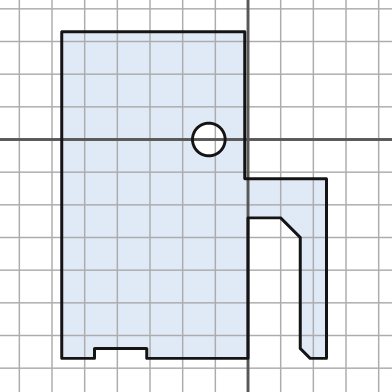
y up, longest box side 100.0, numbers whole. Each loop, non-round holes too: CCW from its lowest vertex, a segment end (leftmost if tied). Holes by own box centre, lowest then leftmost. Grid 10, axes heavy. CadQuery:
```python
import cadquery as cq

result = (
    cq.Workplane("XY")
    .moveTo(-57.0, -67.0)
    .lineTo(-47.0, -67.0)
    .lineTo(-47.0, -64.0)
    .lineTo(-31.0, -64.0)
    .lineTo(-31.0, -67.0)
    .lineTo(0.0, -67.0)
    .lineTo(0.0, -24.0)
    .lineTo(10.0, -24.0)
    .lineTo(16.0, -30.0)
    .lineTo(16.0, -64.0)
    .lineTo(19.0, -67.0)
    .lineTo(24.0, -67.0)
    .lineTo(24.0, -12.0)
    .lineTo(-1.0, -12.0)
    .lineTo(-1.0, 33.0)
    .lineTo(-57.0, 33.0)
    .close()
    .moveTo(-12.0, 0.0)
    .circle(5.0)
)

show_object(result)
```